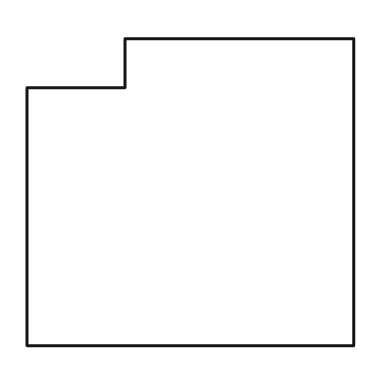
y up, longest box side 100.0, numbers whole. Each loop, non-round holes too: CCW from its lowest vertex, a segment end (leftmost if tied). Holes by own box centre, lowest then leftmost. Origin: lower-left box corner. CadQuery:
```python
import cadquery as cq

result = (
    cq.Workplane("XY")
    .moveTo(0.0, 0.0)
    .lineTo(100.0, 0.0)
    .lineTo(100.0, 94.0)
    .lineTo(30.0, 94.0)
    .lineTo(30.0, 79.0)
    .lineTo(0.0, 79.0)
    .close()
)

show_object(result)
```